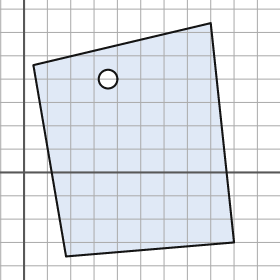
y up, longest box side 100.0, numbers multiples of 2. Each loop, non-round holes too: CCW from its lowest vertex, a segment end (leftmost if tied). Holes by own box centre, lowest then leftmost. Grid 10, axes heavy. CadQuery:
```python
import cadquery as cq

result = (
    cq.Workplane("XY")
    .moveTo(18.0, -36.0)
    .lineTo(90.0, -30.0)
    .lineTo(80.0, 64.0)
    .lineTo(4.0, 46.0)
    .close()
    .moveTo(36.0, 40.0)
    .circle(4.0)
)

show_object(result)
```